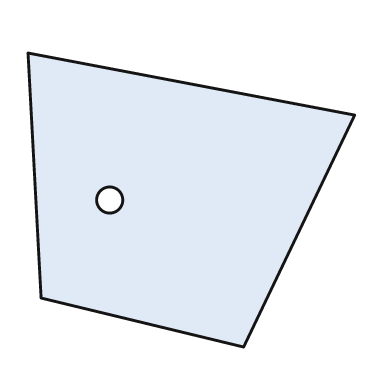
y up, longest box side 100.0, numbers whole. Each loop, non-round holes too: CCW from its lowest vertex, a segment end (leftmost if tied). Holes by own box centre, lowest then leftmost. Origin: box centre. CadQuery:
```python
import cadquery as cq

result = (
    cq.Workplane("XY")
    .moveTo(16.0, -45.0)
    .lineTo(50.0, 26.0)
    .lineTo(-50.0, 45.0)
    .lineTo(-46.0, -30.0)
    .close()
    .moveTo(-25.0, 0.0)
    .circle(4.0)
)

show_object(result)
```